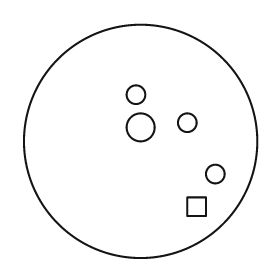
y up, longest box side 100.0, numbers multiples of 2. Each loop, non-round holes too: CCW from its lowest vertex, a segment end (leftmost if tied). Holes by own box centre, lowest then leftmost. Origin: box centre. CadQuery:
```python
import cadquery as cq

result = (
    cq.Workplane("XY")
    .moveTo(0.0, 0.0)
    .circle(50.0)
    .moveTo(20.0, -32.0)
    .lineTo(28.0, -32.0)
    .lineTo(28.0, -24.0)
    .lineTo(20.0, -24.0)
    .close()
    .moveTo(32.0, -14.0)
    .circle(4.0)
    .moveTo(0.0, 6.0)
    .circle(6.0)
    .moveTo(20.0, 8.0)
    .circle(4.0)
    .moveTo(-2.0, 20.0)
    .circle(4.0)
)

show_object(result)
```